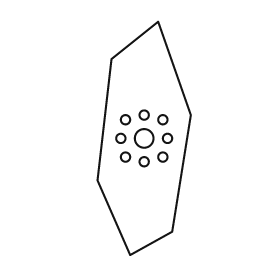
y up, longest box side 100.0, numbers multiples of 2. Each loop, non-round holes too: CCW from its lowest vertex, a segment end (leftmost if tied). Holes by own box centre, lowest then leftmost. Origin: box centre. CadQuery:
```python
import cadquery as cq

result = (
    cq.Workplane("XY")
    .moveTo(-6.0, -50.0)
    .lineTo(12.0, -40.0)
    .lineTo(20.0, 10.0)
    .lineTo(6.0, 50.0)
    .lineTo(-14.0, 34.0)
    .lineTo(-20.0, -18.0)
    .close()
    .moveTo(0.0, -10.0)
    .circle(2.0)
    .moveTo(-8.0, -8.0)
    .circle(2.0)
    .moveTo(8.0, -8.0)
    .circle(2.0)
    .moveTo(-10.0, 0.0)
    .circle(2.0)
    .moveTo(0.0, 0.0)
    .circle(4.0)
    .moveTo(10.0, 0.0)
    .circle(2.0)
    .moveTo(-8.0, 8.0)
    .circle(2.0)
    .moveTo(8.0, 8.0)
    .circle(2.0)
    .moveTo(0.0, 10.0)
    .circle(2.0)
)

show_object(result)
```